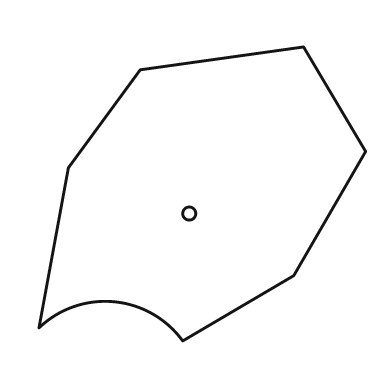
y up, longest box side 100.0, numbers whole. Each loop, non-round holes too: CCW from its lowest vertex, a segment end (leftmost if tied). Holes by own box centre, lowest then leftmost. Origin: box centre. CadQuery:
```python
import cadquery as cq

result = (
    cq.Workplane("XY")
    .moveTo(-6.0, -45.0)
    .lineTo(28.0, -25.0)
    .lineTo(50.0, 13.0)
    .lineTo(31.0, 45.0)
    .lineTo(-19.0, 38.0)
    .lineTo(-41.0, 8.0)
    .lineTo(-50.0, -41.0)
    .threePointArc((-27.0, -33.0), (-6.0, -45.0))
    .close()
    .moveTo(-4.0, -6.0)
    .circle(2.0)
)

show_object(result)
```